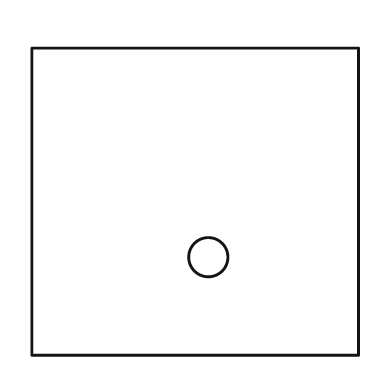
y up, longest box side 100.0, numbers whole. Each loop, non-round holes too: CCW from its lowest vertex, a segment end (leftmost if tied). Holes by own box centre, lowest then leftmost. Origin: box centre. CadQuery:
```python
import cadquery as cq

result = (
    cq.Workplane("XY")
    .moveTo(-50.0, -47.0)
    .lineTo(50.0, -47.0)
    .lineTo(50.0, 47.0)
    .lineTo(-50.0, 47.0)
    .close()
    .moveTo(4.0, -17.0)
    .circle(6.0)
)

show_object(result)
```